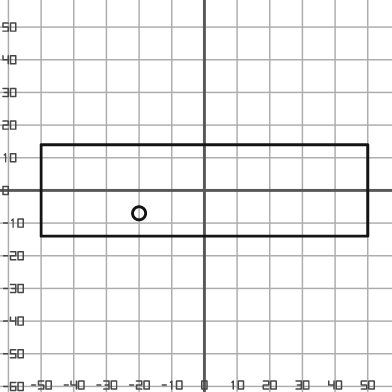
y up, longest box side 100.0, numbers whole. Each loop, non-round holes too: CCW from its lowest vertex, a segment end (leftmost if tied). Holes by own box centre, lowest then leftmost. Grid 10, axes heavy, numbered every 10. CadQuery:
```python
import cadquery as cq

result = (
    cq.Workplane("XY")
    .moveTo(-50.0, -14.0)
    .lineTo(50.0, -14.0)
    .lineTo(50.0, 14.0)
    .lineTo(-50.0, 14.0)
    .close()
    .moveTo(-20.0, -7.0)
    .circle(2.0)
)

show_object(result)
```